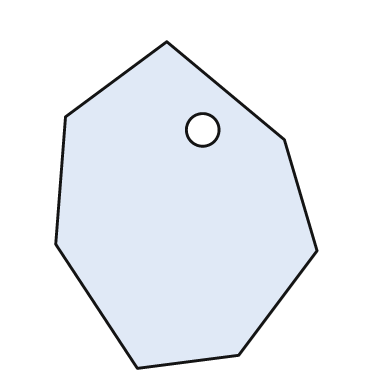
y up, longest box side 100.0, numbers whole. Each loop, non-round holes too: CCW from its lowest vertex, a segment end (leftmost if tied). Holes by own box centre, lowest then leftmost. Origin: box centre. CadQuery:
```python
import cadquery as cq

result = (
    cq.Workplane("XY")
    .moveTo(-15.0, -50.0)
    .lineTo(16.0, -46.0)
    .lineTo(40.0, -14.0)
    .lineTo(30.0, 20.0)
    .lineTo(-6.0, 50.0)
    .lineTo(-37.0, 27.0)
    .lineTo(-40.0, -12.0)
    .close()
    .moveTo(5.0, 23.0)
    .circle(5.0)
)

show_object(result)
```